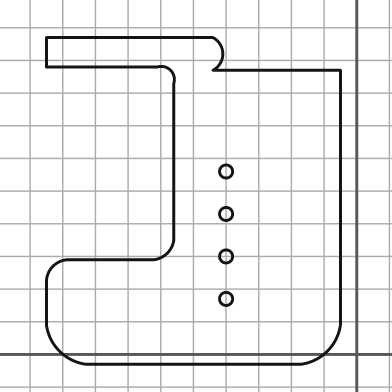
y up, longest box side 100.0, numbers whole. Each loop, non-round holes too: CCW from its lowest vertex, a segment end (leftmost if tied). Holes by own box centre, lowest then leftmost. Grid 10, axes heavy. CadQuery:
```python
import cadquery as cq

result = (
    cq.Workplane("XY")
    .moveTo(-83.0, -3.0)
    .lineTo(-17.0, -3.0)
    .threePointArc((-9.0, 1.0), (-5.0, 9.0))
    .lineTo(-5.0, 87.0)
    .lineTo(-44.0, 87.0)
    .threePointArc((-41.0, 92.0), (-44.0, 97.0))
    .lineTo(-95.0, 97.0)
    .lineTo(-95.0, 88.0)
    .lineTo(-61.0, 88.0)
    .threePointArc((-57.0, 87.0), (-56.0, 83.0))
    .lineTo(-56.0, 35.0)
    .threePointArc((-58.0, 31.0), (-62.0, 29.0))
    .lineTo(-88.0, 29.0)
    .threePointArc((-93.0, 27.0), (-95.0, 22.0))
    .lineTo(-95.0, 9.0)
    .threePointArc((-91.0, 1.0), (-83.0, -3.0))
    .close()
    .moveTo(-40.0, 17.0)
    .circle(2.0)
    .moveTo(-40.0, 30.0)
    .circle(2.0)
    .moveTo(-40.0, 43.0)
    .circle(2.0)
    .moveTo(-40.0, 56.0)
    .circle(2.0)
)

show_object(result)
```